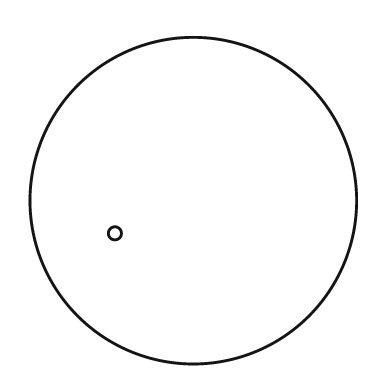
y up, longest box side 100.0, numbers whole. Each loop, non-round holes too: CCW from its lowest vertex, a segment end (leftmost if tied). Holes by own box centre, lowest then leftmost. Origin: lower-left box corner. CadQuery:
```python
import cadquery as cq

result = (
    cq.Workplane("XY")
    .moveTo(50.0, 50.0)
    .circle(50.0)
    .moveTo(26.0, 40.0)
    .circle(2.0)
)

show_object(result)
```